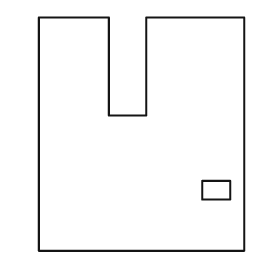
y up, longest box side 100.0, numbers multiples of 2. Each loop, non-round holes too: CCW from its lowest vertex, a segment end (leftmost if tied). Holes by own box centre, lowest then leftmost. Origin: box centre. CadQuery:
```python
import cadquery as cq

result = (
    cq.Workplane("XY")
    .moveTo(-44.0, -50.0)
    .lineTo(44.0, -50.0)
    .lineTo(44.0, 50.0)
    .lineTo(2.0, 50.0)
    .lineTo(2.0, 8.0)
    .lineTo(-14.0, 8.0)
    .lineTo(-14.0, 50.0)
    .lineTo(-44.0, 50.0)
    .close()
    .moveTo(26.0, -28.0)
    .lineTo(38.0, -28.0)
    .lineTo(38.0, -20.0)
    .lineTo(26.0, -20.0)
    .close()
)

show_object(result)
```